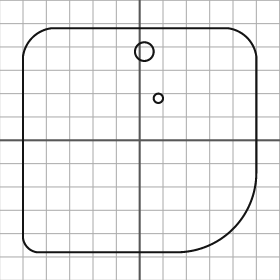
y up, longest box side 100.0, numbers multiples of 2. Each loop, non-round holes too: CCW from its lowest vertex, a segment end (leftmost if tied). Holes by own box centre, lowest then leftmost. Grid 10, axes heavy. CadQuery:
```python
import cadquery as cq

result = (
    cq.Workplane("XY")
    .moveTo(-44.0, -48.0)
    .lineTo(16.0, -48.0)
    .threePointArc((40.0, -38.0), (50.0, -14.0))
    .lineTo(50.0, 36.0)
    .threePointArc((46.0, 44.0), (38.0, 48.0))
    .lineTo(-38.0, 48.0)
    .threePointArc((-46.0, 44.0), (-50.0, 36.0))
    .lineTo(-50.0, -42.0)
    .threePointArc((-48.0, -46.0), (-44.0, -48.0))
    .close()
    .moveTo(8.0, 18.0)
    .circle(2.0)
    .moveTo(2.0, 38.0)
    .circle(4.0)
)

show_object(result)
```